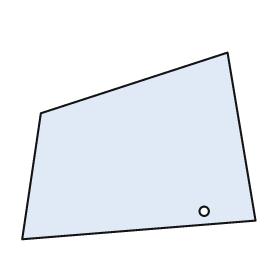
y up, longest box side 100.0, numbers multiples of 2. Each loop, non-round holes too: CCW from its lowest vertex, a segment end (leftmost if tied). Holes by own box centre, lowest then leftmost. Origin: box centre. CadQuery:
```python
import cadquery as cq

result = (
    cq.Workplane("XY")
    .moveTo(-50.0, -40.0)
    .lineTo(50.0, -32.0)
    .lineTo(38.0, 40.0)
    .lineTo(-42.0, 14.0)
    .close()
    .moveTo(28.0, -28.0)
    .circle(2.0)
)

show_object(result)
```